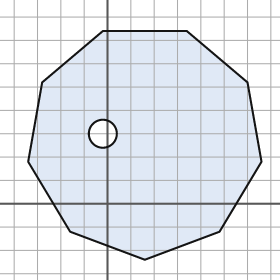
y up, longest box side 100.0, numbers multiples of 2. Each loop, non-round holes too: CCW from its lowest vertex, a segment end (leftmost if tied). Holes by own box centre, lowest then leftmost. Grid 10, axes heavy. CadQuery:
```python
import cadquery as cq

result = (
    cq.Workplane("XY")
    .moveTo(16.0, -24.0)
    .lineTo(48.0, -12.0)
    .lineTo(66.0, 18.0)
    .lineTo(60.0, 52.0)
    .lineTo(34.0, 74.0)
    .lineTo(-2.0, 74.0)
    .lineTo(-28.0, 52.0)
    .lineTo(-34.0, 18.0)
    .lineTo(-16.0, -12.0)
    .close()
    .moveTo(-2.0, 30.0)
    .circle(6.0)
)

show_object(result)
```